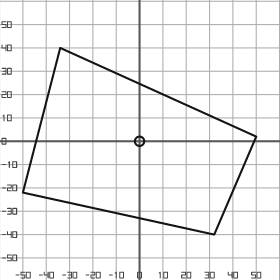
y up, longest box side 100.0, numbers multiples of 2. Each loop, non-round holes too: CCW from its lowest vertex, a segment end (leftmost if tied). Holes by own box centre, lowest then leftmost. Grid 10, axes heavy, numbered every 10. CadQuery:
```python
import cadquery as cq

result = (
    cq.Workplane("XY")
    .moveTo(32.0, -40.0)
    .lineTo(50.0, 2.0)
    .lineTo(-34.0, 40.0)
    .lineTo(-50.0, -22.0)
    .close()
    .moveTo(0.0, 0.0)
    .circle(2.0)
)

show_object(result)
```